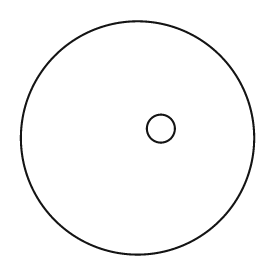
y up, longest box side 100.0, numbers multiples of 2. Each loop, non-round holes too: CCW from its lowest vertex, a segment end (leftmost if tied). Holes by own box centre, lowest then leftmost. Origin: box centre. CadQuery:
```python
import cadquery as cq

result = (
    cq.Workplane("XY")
    .moveTo(0.0, 0.0)
    .circle(50.0)
    .moveTo(10.0, 4.0)
    .circle(6.0)
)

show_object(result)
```